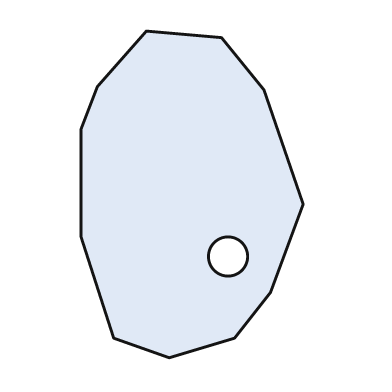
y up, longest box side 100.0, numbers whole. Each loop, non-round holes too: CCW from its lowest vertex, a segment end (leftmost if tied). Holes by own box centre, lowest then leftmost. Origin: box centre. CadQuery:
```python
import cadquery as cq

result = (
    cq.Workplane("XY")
    .moveTo(-7.0, -50.0)
    .lineTo(13.0, -44.0)
    .lineTo(24.0, -30.0)
    .lineTo(34.0, -3.0)
    .lineTo(22.0, 32.0)
    .lineTo(9.0, 48.0)
    .lineTo(-14.0, 50.0)
    .lineTo(-29.0, 33.0)
    .lineTo(-34.0, 20.0)
    .lineTo(-34.0, -13.0)
    .lineTo(-24.0, -44.0)
    .close()
    .moveTo(11.0, -19.0)
    .circle(6.0)
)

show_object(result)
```